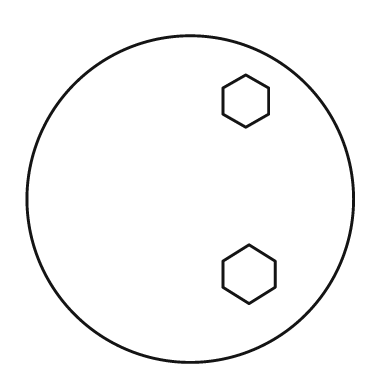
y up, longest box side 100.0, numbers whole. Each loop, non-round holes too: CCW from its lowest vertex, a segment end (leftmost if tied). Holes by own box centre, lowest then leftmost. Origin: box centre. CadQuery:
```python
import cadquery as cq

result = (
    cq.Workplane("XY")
    .moveTo(0.0, 0.0)
    .circle(50.0)
    .moveTo(18.0, -32.0)
    .lineTo(26.0, -27.0)
    .lineTo(26.0, -19.0)
    .lineTo(18.0, -14.0)
    .lineTo(10.0, -19.0)
    .lineTo(10.0, -27.0)
    .close()
    .moveTo(17.0, 22.0)
    .lineTo(24.0, 26.0)
    .lineTo(24.0, 34.0)
    .lineTo(17.0, 38.0)
    .lineTo(10.0, 34.0)
    .lineTo(10.0, 26.0)
    .close()
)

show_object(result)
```